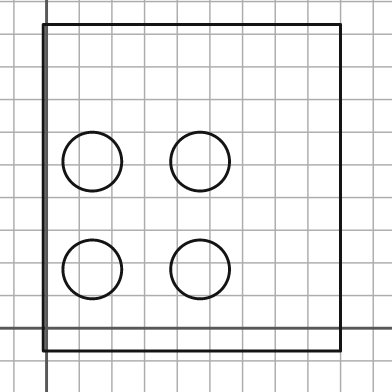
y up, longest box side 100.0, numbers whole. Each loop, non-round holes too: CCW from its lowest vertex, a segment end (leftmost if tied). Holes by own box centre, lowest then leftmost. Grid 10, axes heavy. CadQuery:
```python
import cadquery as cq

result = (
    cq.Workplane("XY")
    .moveTo(-1.0, -7.0)
    .lineTo(90.0, -7.0)
    .lineTo(90.0, 93.0)
    .lineTo(-1.0, 93.0)
    .close()
    .moveTo(14.0, 18.0)
    .circle(9.0)
    .moveTo(47.0, 18.0)
    .circle(9.0)
    .moveTo(14.0, 51.0)
    .circle(9.0)
    .moveTo(47.0, 51.0)
    .circle(9.0)
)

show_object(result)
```